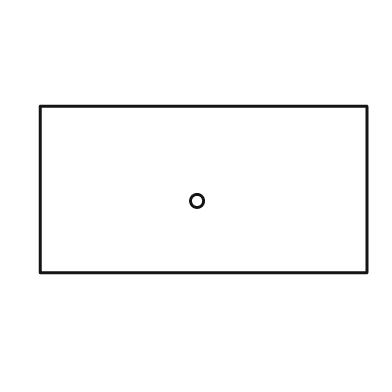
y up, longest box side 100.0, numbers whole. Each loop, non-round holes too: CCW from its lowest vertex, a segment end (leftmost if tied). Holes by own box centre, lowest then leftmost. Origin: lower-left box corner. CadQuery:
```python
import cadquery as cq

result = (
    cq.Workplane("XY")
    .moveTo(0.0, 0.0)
    .lineTo(100.0, 0.0)
    .lineTo(100.0, 51.0)
    .lineTo(0.0, 51.0)
    .close()
    .moveTo(48.0, 22.0)
    .circle(2.0)
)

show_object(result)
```